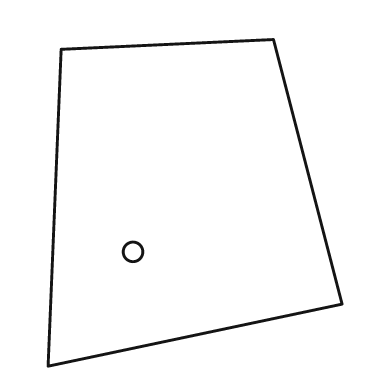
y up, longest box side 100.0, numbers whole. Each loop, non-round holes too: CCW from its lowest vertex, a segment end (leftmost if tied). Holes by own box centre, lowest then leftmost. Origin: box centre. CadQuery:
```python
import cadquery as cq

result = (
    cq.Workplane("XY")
    .moveTo(-45.0, -50.0)
    .lineTo(45.0, -31.0)
    .lineTo(24.0, 50.0)
    .lineTo(-41.0, 47.0)
    .close()
    .moveTo(-19.0, -15.0)
    .circle(3.0)
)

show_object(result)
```